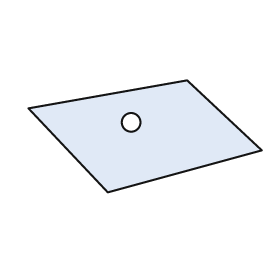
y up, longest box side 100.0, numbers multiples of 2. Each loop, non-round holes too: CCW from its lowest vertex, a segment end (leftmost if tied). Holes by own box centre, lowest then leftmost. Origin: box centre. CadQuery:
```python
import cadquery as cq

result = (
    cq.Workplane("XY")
    .moveTo(-16.0, -24.0)
    .lineTo(50.0, -6.0)
    .lineTo(18.0, 24.0)
    .lineTo(-50.0, 12.0)
    .close()
    .moveTo(-6.0, 6.0)
    .circle(4.0)
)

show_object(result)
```